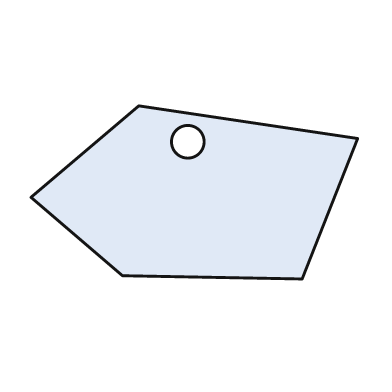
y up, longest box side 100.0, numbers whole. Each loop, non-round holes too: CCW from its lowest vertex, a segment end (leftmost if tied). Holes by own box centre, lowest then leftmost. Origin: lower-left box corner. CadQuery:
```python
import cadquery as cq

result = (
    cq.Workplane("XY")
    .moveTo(83.0, 0.0)
    .lineTo(100.0, 43.0)
    .lineTo(33.0, 53.0)
    .lineTo(0.0, 25.0)
    .lineTo(28.0, 1.0)
    .close()
    .moveTo(48.0, 42.0)
    .circle(5.0)
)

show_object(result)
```